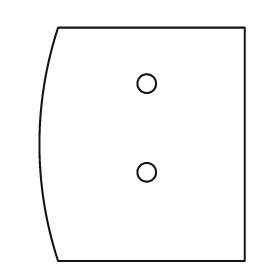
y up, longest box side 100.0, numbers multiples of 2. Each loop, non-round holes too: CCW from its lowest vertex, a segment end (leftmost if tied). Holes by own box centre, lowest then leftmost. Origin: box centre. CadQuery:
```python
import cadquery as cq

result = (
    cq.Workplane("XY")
    .moveTo(-36.0, -50.0)
    .lineTo(44.0, -50.0)
    .lineTo(44.0, 50.0)
    .lineTo(-36.0, 50.0)
    .threePointArc((-44.0, 0.0), (-36.0, -50.0))
    .close()
    .moveTo(2.0, -12.0)
    .circle(4.0)
    .moveTo(2.0, 26.0)
    .circle(4.0)
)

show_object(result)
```